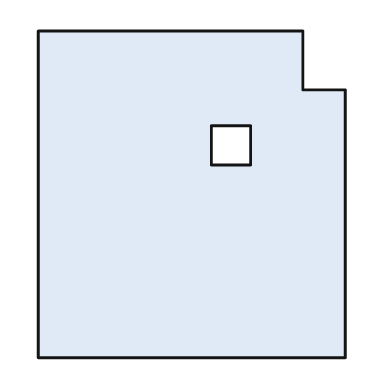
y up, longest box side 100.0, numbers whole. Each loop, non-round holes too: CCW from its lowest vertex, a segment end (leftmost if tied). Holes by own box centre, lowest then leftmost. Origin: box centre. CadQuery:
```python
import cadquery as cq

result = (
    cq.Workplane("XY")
    .moveTo(-47.0, -50.0)
    .lineTo(47.0, -50.0)
    .lineTo(47.0, 32.0)
    .lineTo(34.0, 32.0)
    .lineTo(34.0, 50.0)
    .lineTo(-47.0, 50.0)
    .close()
    .moveTo(6.0, 9.0)
    .lineTo(18.0, 9.0)
    .lineTo(18.0, 21.0)
    .lineTo(6.0, 21.0)
    .close()
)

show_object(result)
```